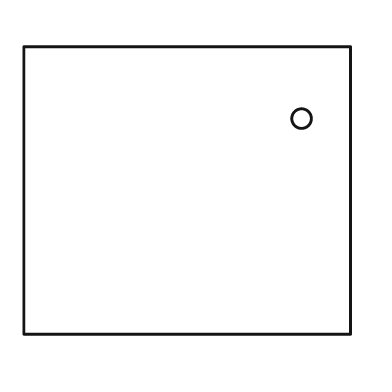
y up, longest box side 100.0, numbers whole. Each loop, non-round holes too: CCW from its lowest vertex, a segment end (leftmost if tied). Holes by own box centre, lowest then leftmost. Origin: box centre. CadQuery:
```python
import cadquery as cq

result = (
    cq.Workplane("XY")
    .moveTo(-50.0, -44.0)
    .lineTo(50.0, -44.0)
    .lineTo(50.0, 44.0)
    .lineTo(-50.0, 44.0)
    .close()
    .moveTo(35.0, 22.0)
    .circle(3.0)
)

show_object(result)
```